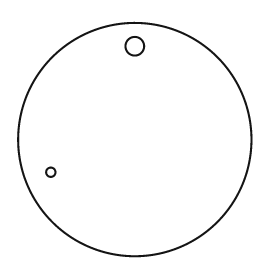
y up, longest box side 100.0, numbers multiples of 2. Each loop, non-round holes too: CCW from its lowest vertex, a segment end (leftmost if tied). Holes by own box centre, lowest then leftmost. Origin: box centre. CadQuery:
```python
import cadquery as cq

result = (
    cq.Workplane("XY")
    .moveTo(0.0, 0.0)
    .circle(50.0)
    .moveTo(-36.0, -14.0)
    .circle(2.0)
    .moveTo(0.0, 40.0)
    .circle(4.0)
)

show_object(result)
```